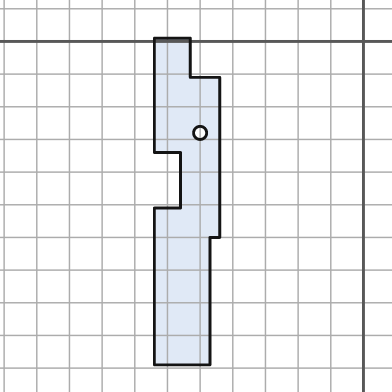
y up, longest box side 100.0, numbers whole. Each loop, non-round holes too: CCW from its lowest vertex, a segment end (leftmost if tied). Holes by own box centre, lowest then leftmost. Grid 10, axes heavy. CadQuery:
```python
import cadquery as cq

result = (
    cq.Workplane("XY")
    .moveTo(-64.0, -99.0)
    .lineTo(-47.0, -99.0)
    .lineTo(-47.0, -60.0)
    .lineTo(-44.0, -60.0)
    .lineTo(-44.0, -11.0)
    .lineTo(-53.0, -11.0)
    .lineTo(-53.0, 1.0)
    .lineTo(-64.0, 1.0)
    .lineTo(-64.0, -34.0)
    .lineTo(-56.0, -34.0)
    .lineTo(-56.0, -51.0)
    .lineTo(-64.0, -51.0)
    .close()
    .moveTo(-50.0, -28.0)
    .circle(2.0)
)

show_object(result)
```